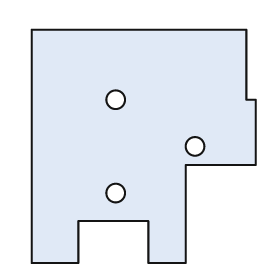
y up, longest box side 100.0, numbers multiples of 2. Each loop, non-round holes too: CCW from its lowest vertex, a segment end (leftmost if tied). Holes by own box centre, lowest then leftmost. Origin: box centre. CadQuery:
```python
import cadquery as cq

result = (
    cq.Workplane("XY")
    .moveTo(-48.0, -50.0)
    .lineTo(-28.0, -50.0)
    .lineTo(-28.0, -32.0)
    .lineTo(2.0, -32.0)
    .lineTo(2.0, -50.0)
    .lineTo(18.0, -50.0)
    .lineTo(18.0, -8.0)
    .lineTo(48.0, -8.0)
    .lineTo(48.0, 20.0)
    .lineTo(44.0, 20.0)
    .lineTo(44.0, 50.0)
    .lineTo(-48.0, 50.0)
    .close()
    .moveTo(-12.0, -20.0)
    .circle(4.0)
    .moveTo(22.0, 0.0)
    .circle(4.0)
    .moveTo(-12.0, 20.0)
    .circle(4.0)
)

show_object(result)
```